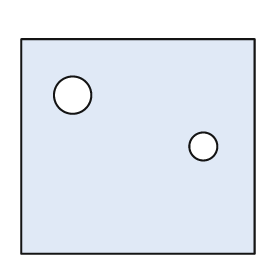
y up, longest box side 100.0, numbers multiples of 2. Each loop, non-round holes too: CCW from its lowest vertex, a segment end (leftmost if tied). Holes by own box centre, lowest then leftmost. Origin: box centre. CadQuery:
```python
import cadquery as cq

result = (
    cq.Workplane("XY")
    .moveTo(-50.0, -46.0)
    .lineTo(50.0, -46.0)
    .lineTo(50.0, 46.0)
    .lineTo(-50.0, 46.0)
    .close()
    .moveTo(28.0, 0.0)
    .circle(6.0)
    .moveTo(-28.0, 22.0)
    .circle(8.0)
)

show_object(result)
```